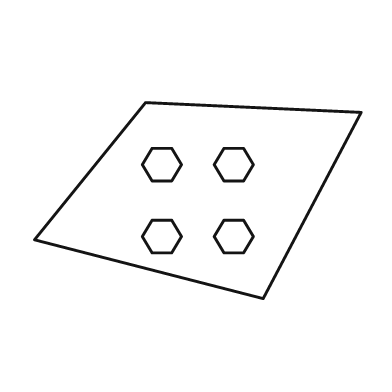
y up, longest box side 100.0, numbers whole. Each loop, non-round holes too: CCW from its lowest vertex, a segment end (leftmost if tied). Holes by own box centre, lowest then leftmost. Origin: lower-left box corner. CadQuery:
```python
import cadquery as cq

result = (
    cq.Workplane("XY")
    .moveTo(70.0, 0.0)
    .lineTo(100.0, 57.0)
    .lineTo(34.0, 60.0)
    .lineTo(0.0, 18.0)
    .close()
    .moveTo(36.0, 14.0)
    .lineTo(42.0, 14.0)
    .lineTo(45.0, 19.0)
    .lineTo(42.0, 24.0)
    .lineTo(36.0, 24.0)
    .lineTo(33.0, 19.0)
    .close()
    .moveTo(58.0, 14.0)
    .lineTo(64.0, 14.0)
    .lineTo(67.0, 19.0)
    .lineTo(64.0, 24.0)
    .lineTo(58.0, 24.0)
    .lineTo(55.0, 19.0)
    .close()
    .moveTo(36.0, 36.0)
    .lineTo(42.0, 36.0)
    .lineTo(45.0, 41.0)
    .lineTo(42.0, 46.0)
    .lineTo(36.0, 46.0)
    .lineTo(33.0, 41.0)
    .close()
    .moveTo(58.0, 36.0)
    .lineTo(64.0, 36.0)
    .lineTo(67.0, 41.0)
    .lineTo(64.0, 46.0)
    .lineTo(58.0, 46.0)
    .lineTo(55.0, 41.0)
    .close()
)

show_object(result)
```